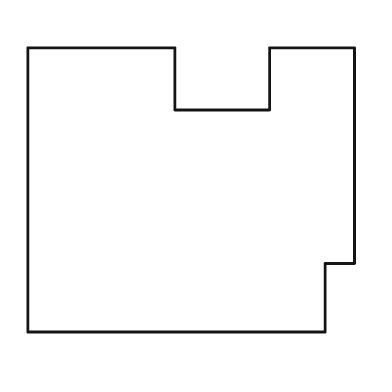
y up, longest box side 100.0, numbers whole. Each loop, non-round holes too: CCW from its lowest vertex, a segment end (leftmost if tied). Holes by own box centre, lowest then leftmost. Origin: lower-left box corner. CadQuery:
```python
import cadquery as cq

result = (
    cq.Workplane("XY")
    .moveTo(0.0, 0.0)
    .lineTo(91.0, 0.0)
    .lineTo(91.0, 21.0)
    .lineTo(100.0, 21.0)
    .lineTo(100.0, 87.0)
    .lineTo(74.0, 87.0)
    .lineTo(74.0, 68.0)
    .lineTo(45.0, 68.0)
    .lineTo(45.0, 87.0)
    .lineTo(0.0, 87.0)
    .close()
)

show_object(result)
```